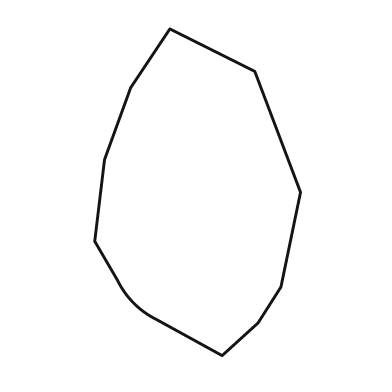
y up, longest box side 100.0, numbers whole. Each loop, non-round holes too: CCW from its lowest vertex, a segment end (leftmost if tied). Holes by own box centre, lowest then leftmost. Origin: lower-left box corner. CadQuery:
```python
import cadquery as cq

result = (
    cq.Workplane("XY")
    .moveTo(39.0, 0.0)
    .lineTo(50.0, 10.0)
    .lineTo(57.0, 21.0)
    .lineTo(63.0, 50.0)
    .lineTo(49.0, 87.0)
    .lineTo(23.0, 100.0)
    .lineTo(11.0, 82.0)
    .lineTo(3.0, 60.0)
    .lineTo(0.0, 35.0)
    .lineTo(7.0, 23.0)
    .threePointArc((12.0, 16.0), (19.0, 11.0))
    .close()
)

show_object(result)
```